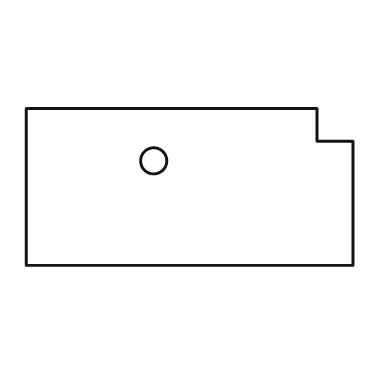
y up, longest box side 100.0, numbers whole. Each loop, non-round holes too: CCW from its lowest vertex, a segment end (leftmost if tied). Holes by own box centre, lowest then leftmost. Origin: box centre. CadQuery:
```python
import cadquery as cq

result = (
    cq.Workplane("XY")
    .moveTo(-50.0, -24.0)
    .lineTo(50.0, -24.0)
    .lineTo(50.0, 14.0)
    .lineTo(39.0, 14.0)
    .lineTo(39.0, 24.0)
    .lineTo(-50.0, 24.0)
    .close()
    .moveTo(-11.0, 8.0)
    .circle(4.0)
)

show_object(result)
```